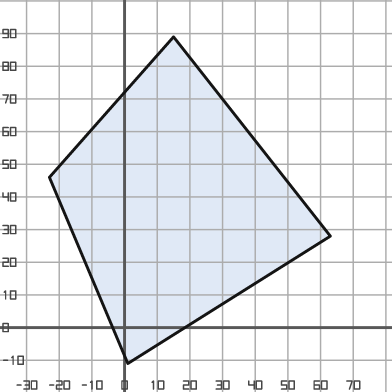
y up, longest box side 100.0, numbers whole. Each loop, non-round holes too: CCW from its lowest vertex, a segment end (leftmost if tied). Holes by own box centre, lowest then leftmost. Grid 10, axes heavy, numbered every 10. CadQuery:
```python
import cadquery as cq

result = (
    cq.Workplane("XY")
    .moveTo(1.0, -11.0)
    .lineTo(63.0, 28.0)
    .lineTo(15.0, 89.0)
    .lineTo(-23.0, 46.0)
    .close()
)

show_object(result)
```